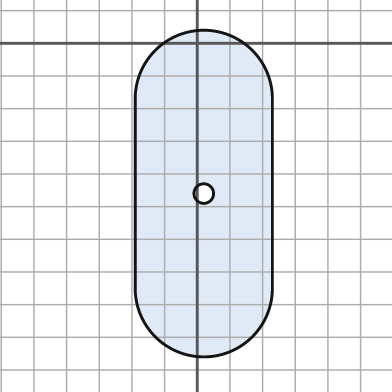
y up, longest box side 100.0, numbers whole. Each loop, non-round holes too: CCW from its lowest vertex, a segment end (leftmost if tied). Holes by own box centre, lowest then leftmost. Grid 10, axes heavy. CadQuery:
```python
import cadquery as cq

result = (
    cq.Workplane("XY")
    .moveTo(-19.0, -75.0)
    .threePointArc((2.0, -96.0), (23.0, -75.0))
    .lineTo(23.0, -17.0)
    .threePointArc((2.0, 4.0), (-19.0, -17.0))
    .close()
    .moveTo(2.0, -46.0)
    .circle(3.0)
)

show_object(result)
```